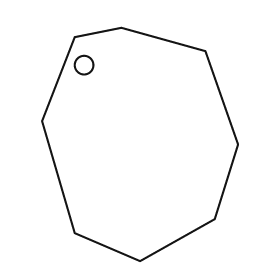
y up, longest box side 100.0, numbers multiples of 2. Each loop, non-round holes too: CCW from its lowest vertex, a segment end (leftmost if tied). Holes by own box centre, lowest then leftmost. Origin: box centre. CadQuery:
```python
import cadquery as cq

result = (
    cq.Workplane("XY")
    .moveTo(0.0, -50.0)
    .lineTo(32.0, -32.0)
    .lineTo(42.0, 0.0)
    .lineTo(28.0, 40.0)
    .lineTo(-8.0, 50.0)
    .lineTo(-28.0, 46.0)
    .lineTo(-42.0, 10.0)
    .lineTo(-28.0, -38.0)
    .close()
    .moveTo(-24.0, 34.0)
    .circle(4.0)
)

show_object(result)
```